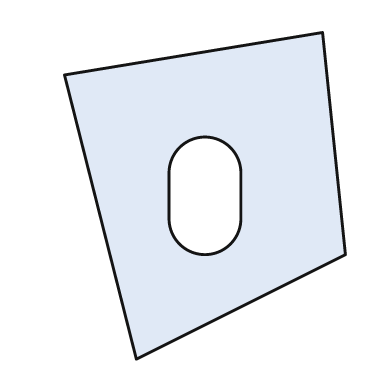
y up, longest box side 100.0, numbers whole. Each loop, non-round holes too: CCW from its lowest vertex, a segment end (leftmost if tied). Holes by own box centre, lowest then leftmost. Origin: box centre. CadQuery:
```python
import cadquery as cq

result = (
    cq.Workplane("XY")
    .moveTo(-21.0, -50.0)
    .lineTo(43.0, -18.0)
    .lineTo(36.0, 50.0)
    .lineTo(-43.0, 37.0)
    .close()
    .moveTo(-11.0, -7.0)
    .threePointArc((0.0, -18.0), (11.0, -7.0))
    .lineTo(11.0, 7.0)
    .threePointArc((0.0, 18.0), (-11.0, 7.0))
    .close()
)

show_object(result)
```